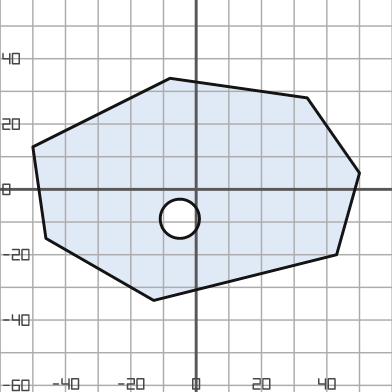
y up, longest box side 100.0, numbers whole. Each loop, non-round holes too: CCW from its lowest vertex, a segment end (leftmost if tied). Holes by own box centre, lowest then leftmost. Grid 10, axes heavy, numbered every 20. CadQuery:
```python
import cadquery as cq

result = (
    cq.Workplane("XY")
    .moveTo(-13.0, -34.0)
    .lineTo(43.0, -20.0)
    .lineTo(50.0, 5.0)
    .lineTo(34.0, 28.0)
    .lineTo(-8.0, 34.0)
    .lineTo(-50.0, 13.0)
    .lineTo(-46.0, -15.0)
    .close()
    .moveTo(-5.0, -9.0)
    .circle(6.0)
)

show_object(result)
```